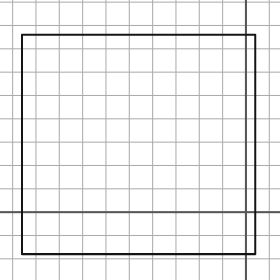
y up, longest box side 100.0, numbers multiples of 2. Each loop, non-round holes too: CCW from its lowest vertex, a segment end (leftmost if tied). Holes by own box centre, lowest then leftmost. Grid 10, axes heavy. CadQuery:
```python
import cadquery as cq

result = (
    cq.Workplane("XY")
    .moveTo(-96.0, -18.0)
    .lineTo(4.0, -18.0)
    .lineTo(4.0, 76.0)
    .lineTo(-96.0, 76.0)
    .close()
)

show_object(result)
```